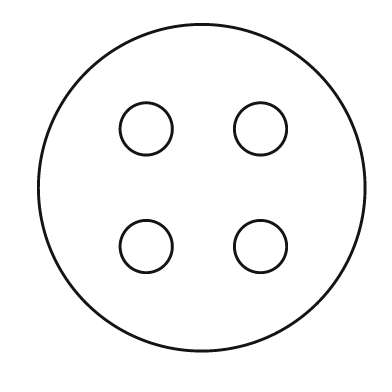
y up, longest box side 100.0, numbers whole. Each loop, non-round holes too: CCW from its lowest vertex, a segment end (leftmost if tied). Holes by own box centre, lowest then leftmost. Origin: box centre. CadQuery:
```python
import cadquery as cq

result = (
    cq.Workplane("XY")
    .moveTo(0.0, 0.0)
    .circle(50.0)
    .moveTo(-17.0, -18.0)
    .circle(8.0)
    .moveTo(18.0, -18.0)
    .circle(8.0)
    .moveTo(-17.0, 18.0)
    .circle(8.0)
    .moveTo(18.0, 18.0)
    .circle(8.0)
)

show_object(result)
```